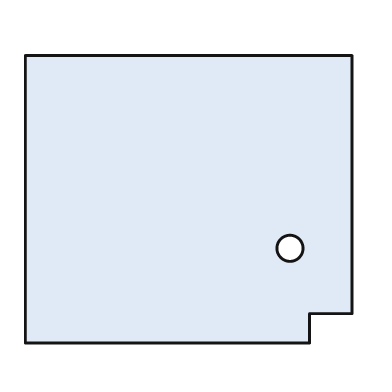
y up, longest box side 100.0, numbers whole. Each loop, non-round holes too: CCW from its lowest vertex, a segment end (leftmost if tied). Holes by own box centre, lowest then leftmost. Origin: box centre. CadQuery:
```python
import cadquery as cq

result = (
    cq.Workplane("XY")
    .moveTo(-50.0, -44.0)
    .lineTo(37.0, -44.0)
    .lineTo(37.0, -35.0)
    .lineTo(50.0, -35.0)
    .lineTo(50.0, 44.0)
    .lineTo(-50.0, 44.0)
    .close()
    .moveTo(31.0, -15.0)
    .circle(4.0)
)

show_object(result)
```